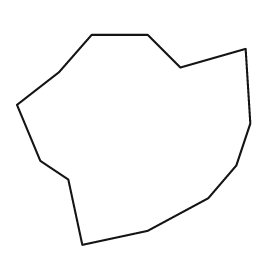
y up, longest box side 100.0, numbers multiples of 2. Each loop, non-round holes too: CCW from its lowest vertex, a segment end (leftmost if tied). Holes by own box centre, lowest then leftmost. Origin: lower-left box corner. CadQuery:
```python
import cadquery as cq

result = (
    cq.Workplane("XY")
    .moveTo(28.0, 0.0)
    .lineTo(56.0, 6.0)
    .lineTo(82.0, 20.0)
    .lineTo(94.0, 34.0)
    .lineTo(100.0, 52.0)
    .lineTo(98.0, 84.0)
    .lineTo(70.0, 76.0)
    .lineTo(56.0, 90.0)
    .lineTo(32.0, 90.0)
    .lineTo(18.0, 74.0)
    .lineTo(0.0, 60.0)
    .lineTo(10.0, 36.0)
    .lineTo(22.0, 28.0)
    .close()
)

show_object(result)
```